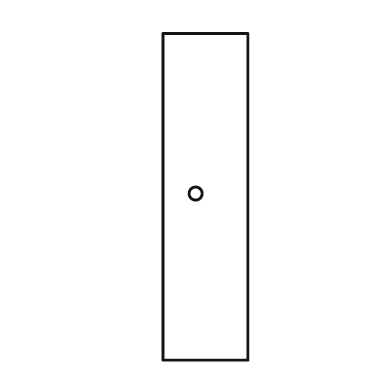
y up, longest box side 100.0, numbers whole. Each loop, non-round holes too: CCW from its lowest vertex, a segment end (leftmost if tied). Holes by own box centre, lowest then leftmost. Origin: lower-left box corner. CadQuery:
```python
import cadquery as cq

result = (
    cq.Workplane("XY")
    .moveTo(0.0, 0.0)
    .lineTo(26.0, 0.0)
    .lineTo(26.0, 100.0)
    .lineTo(0.0, 100.0)
    .close()
    .moveTo(10.0, 51.0)
    .circle(2.0)
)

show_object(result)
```